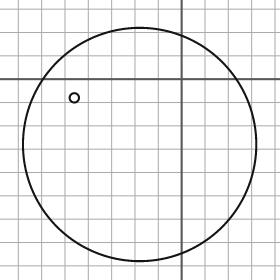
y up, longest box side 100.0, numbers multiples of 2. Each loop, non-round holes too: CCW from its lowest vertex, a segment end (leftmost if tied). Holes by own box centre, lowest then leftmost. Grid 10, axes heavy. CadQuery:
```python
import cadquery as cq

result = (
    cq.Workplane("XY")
    .moveTo(-18.0, -28.0)
    .circle(50.0)
    .moveTo(-46.0, -8.0)
    .circle(2.0)
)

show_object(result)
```